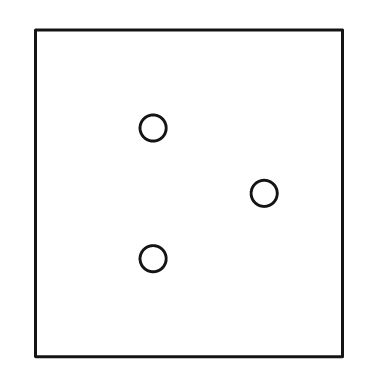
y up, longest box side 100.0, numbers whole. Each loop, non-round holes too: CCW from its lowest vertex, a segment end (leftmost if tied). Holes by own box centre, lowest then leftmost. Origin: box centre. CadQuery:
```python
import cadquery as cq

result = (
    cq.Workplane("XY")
    .moveTo(-47.0, -50.0)
    .lineTo(47.0, -50.0)
    .lineTo(47.0, 50.0)
    .lineTo(-47.0, 50.0)
    .close()
    .moveTo(-11.0, -20.0)
    .circle(4.0)
    .moveTo(23.0, 0.0)
    .circle(4.0)
    .moveTo(-11.0, 20.0)
    .circle(4.0)
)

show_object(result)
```